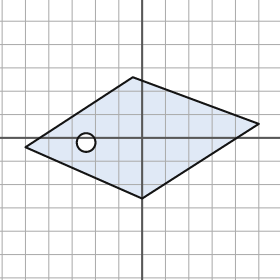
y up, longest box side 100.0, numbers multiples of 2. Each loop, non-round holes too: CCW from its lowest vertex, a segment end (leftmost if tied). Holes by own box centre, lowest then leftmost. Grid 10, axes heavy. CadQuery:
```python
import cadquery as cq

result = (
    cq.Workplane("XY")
    .moveTo(0.0, -26.0)
    .lineTo(50.0, 6.0)
    .lineTo(-4.0, 26.0)
    .lineTo(-50.0, -4.0)
    .close()
    .moveTo(-24.0, -2.0)
    .circle(4.0)
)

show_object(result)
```